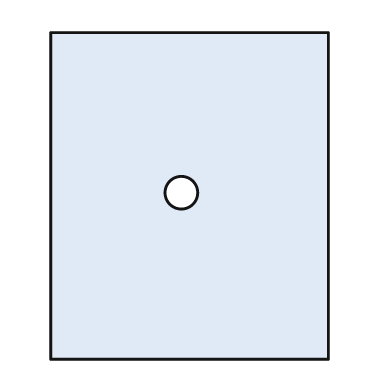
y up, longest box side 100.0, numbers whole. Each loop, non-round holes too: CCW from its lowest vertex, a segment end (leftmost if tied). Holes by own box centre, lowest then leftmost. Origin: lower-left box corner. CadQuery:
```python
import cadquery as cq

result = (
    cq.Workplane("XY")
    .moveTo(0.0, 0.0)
    .lineTo(85.0, 0.0)
    .lineTo(85.0, 100.0)
    .lineTo(0.0, 100.0)
    .close()
    .moveTo(40.0, 51.0)
    .circle(5.0)
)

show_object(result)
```